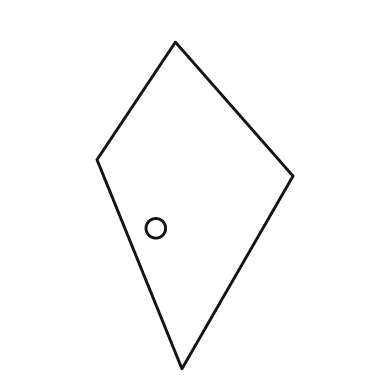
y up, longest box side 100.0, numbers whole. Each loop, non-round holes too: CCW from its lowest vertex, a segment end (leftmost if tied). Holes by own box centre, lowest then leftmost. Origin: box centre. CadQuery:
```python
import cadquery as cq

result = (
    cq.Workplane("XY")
    .moveTo(-4.0, -50.0)
    .lineTo(30.0, 9.0)
    .lineTo(-6.0, 50.0)
    .lineTo(-30.0, 14.0)
    .close()
    .moveTo(-12.0, -7.0)
    .circle(3.0)
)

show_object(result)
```